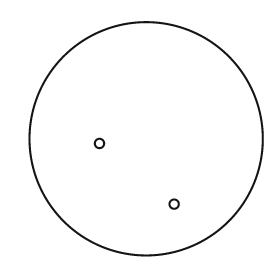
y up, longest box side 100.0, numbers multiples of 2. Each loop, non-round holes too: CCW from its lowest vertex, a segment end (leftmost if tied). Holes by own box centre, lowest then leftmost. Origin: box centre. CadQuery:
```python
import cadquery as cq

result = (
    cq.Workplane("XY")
    .moveTo(0.0, 0.0)
    .circle(50.0)
    .moveTo(12.0, -28.0)
    .circle(2.0)
    .moveTo(-20.0, -2.0)
    .circle(2.0)
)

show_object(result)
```